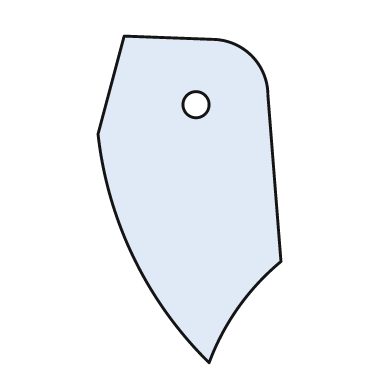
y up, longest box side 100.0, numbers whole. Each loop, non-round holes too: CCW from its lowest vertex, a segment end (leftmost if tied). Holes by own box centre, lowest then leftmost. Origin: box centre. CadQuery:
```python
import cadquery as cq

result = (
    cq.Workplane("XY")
    .moveTo(6.0, -50.0)
    .threePointArc((15.0, -33.0), (28.0, -19.0))
    .lineTo(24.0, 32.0)
    .threePointArc((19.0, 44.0), (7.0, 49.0))
    .lineTo(-20.0, 50.0)
    .lineTo(-28.0, 20.0)
    .threePointArc((-17.0, -18.0), (6.0, -50.0))
    .close()
    .moveTo(2.0, 29.0)
    .circle(4.0)
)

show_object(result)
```